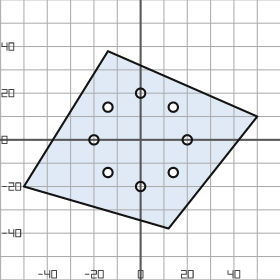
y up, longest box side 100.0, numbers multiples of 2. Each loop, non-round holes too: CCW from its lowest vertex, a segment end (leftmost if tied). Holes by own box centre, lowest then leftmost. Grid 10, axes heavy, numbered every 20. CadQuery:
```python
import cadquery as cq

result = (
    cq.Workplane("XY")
    .moveTo(12.0, -38.0)
    .lineTo(50.0, 10.0)
    .lineTo(-14.0, 38.0)
    .lineTo(-50.0, -20.0)
    .close()
    .moveTo(0.0, -20.0)
    .circle(2.0)
    .moveTo(-14.0, -14.0)
    .circle(2.0)
    .moveTo(14.0, -14.0)
    .circle(2.0)
    .moveTo(-20.0, 0.0)
    .circle(2.0)
    .moveTo(20.0, 0.0)
    .circle(2.0)
    .moveTo(-14.0, 14.0)
    .circle(2.0)
    .moveTo(14.0, 14.0)
    .circle(2.0)
    .moveTo(0.0, 20.0)
    .circle(2.0)
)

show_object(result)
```